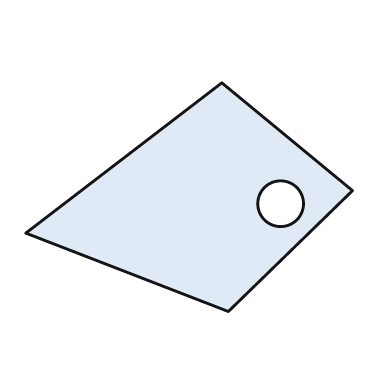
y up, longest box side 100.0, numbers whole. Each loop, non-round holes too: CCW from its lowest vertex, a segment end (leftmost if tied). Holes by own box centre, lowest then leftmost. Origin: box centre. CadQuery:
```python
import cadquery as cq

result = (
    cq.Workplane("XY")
    .moveTo(12.0, -35.0)
    .lineTo(50.0, 2.0)
    .lineTo(10.0, 35.0)
    .lineTo(-50.0, -11.0)
    .close()
    .moveTo(28.0, -2.0)
    .circle(7.0)
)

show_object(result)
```